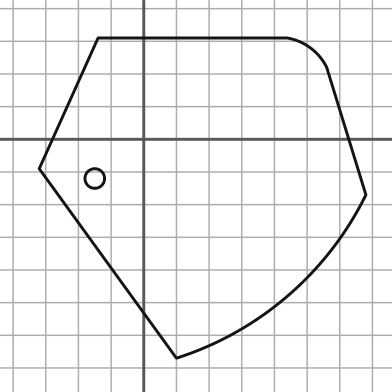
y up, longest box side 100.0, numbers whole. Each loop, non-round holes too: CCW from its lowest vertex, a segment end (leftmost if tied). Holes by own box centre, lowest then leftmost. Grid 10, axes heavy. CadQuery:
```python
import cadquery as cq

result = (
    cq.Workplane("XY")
    .moveTo(10.0, -67.0)
    .threePointArc((44.0, -48.0), (68.0, -17.0))
    .lineTo(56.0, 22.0)
    .threePointArc((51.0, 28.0), (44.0, 31.0))
    .lineTo(-14.0, 31.0)
    .lineTo(-32.0, -9.0)
    .close()
    .moveTo(-15.0, -12.0)
    .circle(3.0)
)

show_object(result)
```